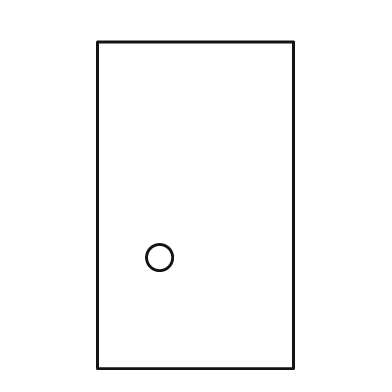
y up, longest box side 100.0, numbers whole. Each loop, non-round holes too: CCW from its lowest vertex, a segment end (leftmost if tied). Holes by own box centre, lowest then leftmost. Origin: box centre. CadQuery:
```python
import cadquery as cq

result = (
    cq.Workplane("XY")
    .moveTo(-30.0, -50.0)
    .lineTo(30.0, -50.0)
    .lineTo(30.0, 50.0)
    .lineTo(-30.0, 50.0)
    .close()
    .moveTo(-11.0, -16.0)
    .circle(4.0)
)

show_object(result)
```